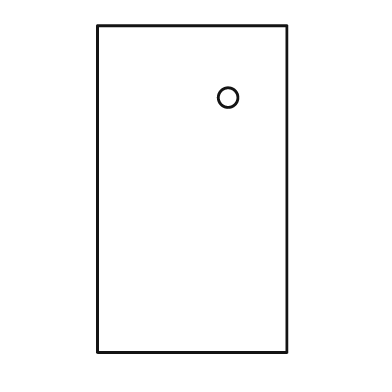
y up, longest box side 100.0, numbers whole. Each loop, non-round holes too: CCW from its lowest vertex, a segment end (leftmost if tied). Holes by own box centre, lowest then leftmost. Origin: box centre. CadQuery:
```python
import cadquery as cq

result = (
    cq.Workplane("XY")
    .moveTo(-29.0, -50.0)
    .lineTo(29.0, -50.0)
    .lineTo(29.0, 50.0)
    .lineTo(-29.0, 50.0)
    .close()
    .moveTo(11.0, 28.0)
    .circle(3.0)
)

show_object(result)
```